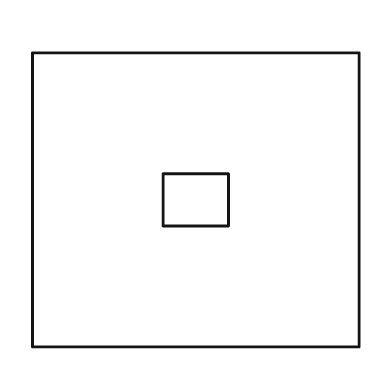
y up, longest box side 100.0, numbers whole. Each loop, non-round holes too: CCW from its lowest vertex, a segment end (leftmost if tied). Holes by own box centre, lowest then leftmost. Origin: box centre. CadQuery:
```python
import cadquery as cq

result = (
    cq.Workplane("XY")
    .moveTo(-50.0, -45.0)
    .lineTo(50.0, -45.0)
    .lineTo(50.0, 45.0)
    .lineTo(-50.0, 45.0)
    .close()
    .moveTo(-10.0, -8.0)
    .lineTo(10.0, -8.0)
    .lineTo(10.0, 8.0)
    .lineTo(-10.0, 8.0)
    .close()
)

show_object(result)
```